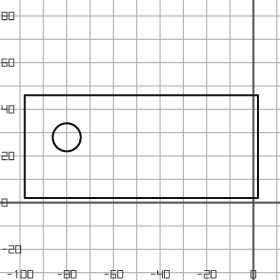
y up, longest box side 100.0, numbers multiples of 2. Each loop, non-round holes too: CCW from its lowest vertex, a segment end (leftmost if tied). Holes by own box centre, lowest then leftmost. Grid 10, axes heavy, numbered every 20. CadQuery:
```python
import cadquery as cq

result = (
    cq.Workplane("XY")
    .moveTo(-98.0, 2.0)
    .lineTo(2.0, 2.0)
    .lineTo(2.0, 46.0)
    .lineTo(-98.0, 46.0)
    .close()
    .moveTo(-80.0, 28.0)
    .circle(6.0)
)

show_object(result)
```